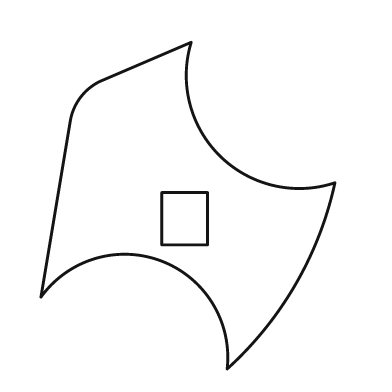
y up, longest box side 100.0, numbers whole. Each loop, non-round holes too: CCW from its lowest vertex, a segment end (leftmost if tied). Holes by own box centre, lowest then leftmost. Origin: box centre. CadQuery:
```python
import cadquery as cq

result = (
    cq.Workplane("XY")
    .moveTo(12.0, -50.0)
    .threePointArc((33.0, -24.0), (45.0, 7.0))
    .threePointArc((10.0, 15.0), (1.0, 50.0))
    .lineTo(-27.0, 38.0)
    .threePointArc((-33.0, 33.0), (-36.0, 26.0))
    .lineTo(-45.0, -28.0)
    .threePointArc((-8.0, -17.0), (12.0, -50.0))
    .close()
    .moveTo(-8.0, -12.0)
    .lineTo(6.0, -12.0)
    .lineTo(6.0, 4.0)
    .lineTo(-8.0, 4.0)
    .close()
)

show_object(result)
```